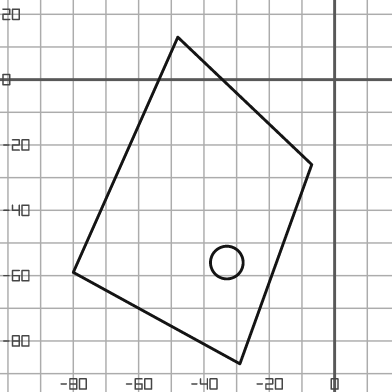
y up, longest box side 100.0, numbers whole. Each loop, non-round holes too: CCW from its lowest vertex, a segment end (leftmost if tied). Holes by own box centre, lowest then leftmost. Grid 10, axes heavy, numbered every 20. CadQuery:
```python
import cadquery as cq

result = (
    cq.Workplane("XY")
    .moveTo(-29.0, -87.0)
    .lineTo(-7.0, -26.0)
    .lineTo(-48.0, 13.0)
    .lineTo(-80.0, -59.0)
    .close()
    .moveTo(-33.0, -56.0)
    .circle(5.0)
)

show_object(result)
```